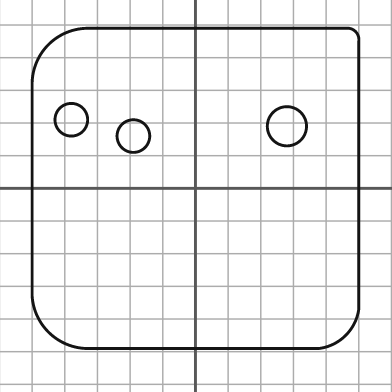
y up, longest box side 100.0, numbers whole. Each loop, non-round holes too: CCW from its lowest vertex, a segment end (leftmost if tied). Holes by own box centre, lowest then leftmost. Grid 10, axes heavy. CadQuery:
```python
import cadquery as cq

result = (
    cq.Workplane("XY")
    .moveTo(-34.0, -49.0)
    .lineTo(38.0, -49.0)
    .threePointArc((46.0, -45.0), (50.0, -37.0))
    .lineTo(50.0, 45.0)
    .threePointArc((49.0, 48.0), (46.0, 49.0))
    .lineTo(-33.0, 49.0)
    .threePointArc((-45.0, 44.0), (-50.0, 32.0))
    .lineTo(-50.0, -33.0)
    .threePointArc((-45.0, -44.0), (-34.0, -49.0))
    .close()
    .moveTo(-19.0, 16.0)
    .circle(5.0)
    .moveTo(28.0, 19.0)
    .circle(6.0)
    .moveTo(-38.0, 21.0)
    .circle(5.0)
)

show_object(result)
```